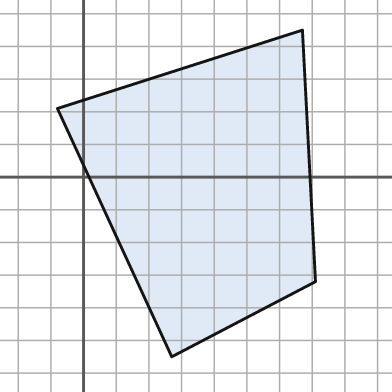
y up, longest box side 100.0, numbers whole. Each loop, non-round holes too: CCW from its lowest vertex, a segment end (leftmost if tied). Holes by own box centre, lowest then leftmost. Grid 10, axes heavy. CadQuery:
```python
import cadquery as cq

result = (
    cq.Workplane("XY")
    .moveTo(27.0, -55.0)
    .lineTo(71.0, -32.0)
    .lineTo(67.0, 45.0)
    .lineTo(-8.0, 21.0)
    .close()
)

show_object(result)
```